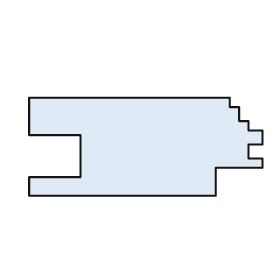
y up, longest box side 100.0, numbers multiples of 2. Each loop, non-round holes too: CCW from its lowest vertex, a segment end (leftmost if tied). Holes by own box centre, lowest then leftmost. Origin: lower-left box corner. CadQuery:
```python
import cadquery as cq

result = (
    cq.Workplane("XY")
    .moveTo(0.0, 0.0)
    .lineTo(80.0, 0.0)
    .lineTo(80.0, 12.0)
    .lineTo(100.0, 12.0)
    .lineTo(100.0, 16.0)
    .lineTo(94.0, 16.0)
    .lineTo(94.0, 22.0)
    .lineTo(100.0, 22.0)
    .lineTo(100.0, 28.0)
    .lineTo(94.0, 28.0)
    .lineTo(94.0, 32.0)
    .lineTo(90.0, 32.0)
    .lineTo(90.0, 38.0)
    .lineTo(86.0, 38.0)
    .lineTo(86.0, 42.0)
    .lineTo(0.0, 42.0)
    .lineTo(0.0, 26.0)
    .lineTo(22.0, 26.0)
    .lineTo(22.0, 8.0)
    .lineTo(0.0, 8.0)
    .close()
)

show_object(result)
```